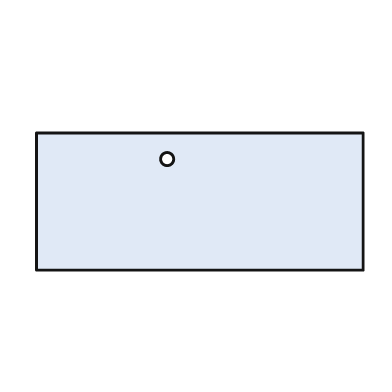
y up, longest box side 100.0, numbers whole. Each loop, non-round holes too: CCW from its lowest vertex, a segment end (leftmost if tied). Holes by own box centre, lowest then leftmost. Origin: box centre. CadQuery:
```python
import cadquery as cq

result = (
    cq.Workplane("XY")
    .moveTo(-50.0, -21.0)
    .lineTo(50.0, -21.0)
    .lineTo(50.0, 21.0)
    .lineTo(-50.0, 21.0)
    .close()
    .moveTo(-10.0, 13.0)
    .circle(2.0)
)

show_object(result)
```